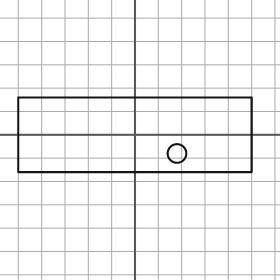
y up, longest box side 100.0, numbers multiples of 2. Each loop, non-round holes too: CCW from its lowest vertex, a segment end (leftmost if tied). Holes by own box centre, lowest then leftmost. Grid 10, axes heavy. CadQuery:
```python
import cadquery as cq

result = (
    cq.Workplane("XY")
    .moveTo(-50.0, -16.0)
    .lineTo(50.0, -16.0)
    .lineTo(50.0, 16.0)
    .lineTo(-50.0, 16.0)
    .close()
    .moveTo(18.0, -8.0)
    .circle(4.0)
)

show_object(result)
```